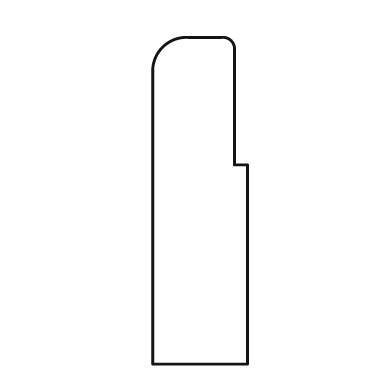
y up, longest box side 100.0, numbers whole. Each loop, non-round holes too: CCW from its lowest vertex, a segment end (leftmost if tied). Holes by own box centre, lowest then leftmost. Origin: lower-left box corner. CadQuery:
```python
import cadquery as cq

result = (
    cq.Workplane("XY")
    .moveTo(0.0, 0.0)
    .lineTo(29.0, 0.0)
    .lineTo(29.0, 61.0)
    .lineTo(25.0, 61.0)
    .lineTo(25.0, 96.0)
    .threePointArc((24.0, 99.0), (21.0, 100.0))
    .lineTo(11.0, 100.0)
    .threePointArc((3.0, 97.0), (0.0, 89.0))
    .close()
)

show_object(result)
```